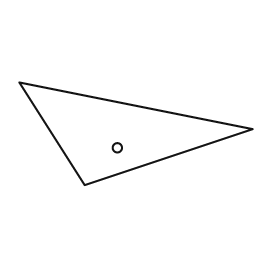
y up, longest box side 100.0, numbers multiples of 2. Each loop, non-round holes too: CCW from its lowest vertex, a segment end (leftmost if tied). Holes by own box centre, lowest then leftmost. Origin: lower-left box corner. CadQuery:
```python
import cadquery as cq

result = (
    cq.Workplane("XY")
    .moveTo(28.0, 0.0)
    .lineTo(100.0, 24.0)
    .lineTo(0.0, 44.0)
    .close()
    .moveTo(42.0, 16.0)
    .circle(2.0)
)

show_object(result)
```